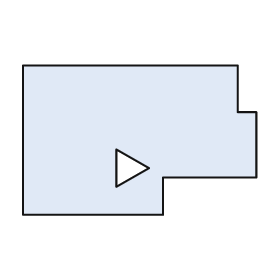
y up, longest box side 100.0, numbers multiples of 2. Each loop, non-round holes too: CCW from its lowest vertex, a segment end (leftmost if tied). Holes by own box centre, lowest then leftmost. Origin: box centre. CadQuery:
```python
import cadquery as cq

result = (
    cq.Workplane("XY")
    .moveTo(-50.0, -32.0)
    .lineTo(10.0, -32.0)
    .lineTo(10.0, -16.0)
    .lineTo(50.0, -16.0)
    .lineTo(50.0, 12.0)
    .lineTo(42.0, 12.0)
    .lineTo(42.0, 32.0)
    .lineTo(-50.0, 32.0)
    .close()
    .moveTo(-10.0, -20.0)
    .lineTo(4.0, -12.0)
    .lineTo(-10.0, -4.0)
    .close()
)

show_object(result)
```